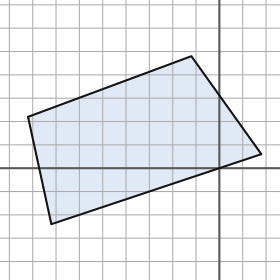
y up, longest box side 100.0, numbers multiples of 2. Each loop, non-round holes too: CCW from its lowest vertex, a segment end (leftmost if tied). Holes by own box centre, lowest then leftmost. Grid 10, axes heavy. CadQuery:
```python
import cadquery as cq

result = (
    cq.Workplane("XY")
    .moveTo(-72.0, -24.0)
    .lineTo(18.0, 6.0)
    .lineTo(-12.0, 48.0)
    .lineTo(-82.0, 22.0)
    .close()
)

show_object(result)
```